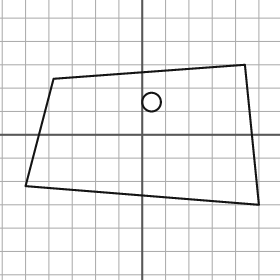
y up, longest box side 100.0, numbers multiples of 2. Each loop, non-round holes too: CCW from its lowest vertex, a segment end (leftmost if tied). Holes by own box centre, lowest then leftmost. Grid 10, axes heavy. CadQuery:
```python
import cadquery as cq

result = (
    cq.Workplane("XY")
    .moveTo(50.0, -30.0)
    .lineTo(44.0, 30.0)
    .lineTo(-38.0, 24.0)
    .lineTo(-50.0, -22.0)
    .close()
    .moveTo(4.0, 14.0)
    .circle(4.0)
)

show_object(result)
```